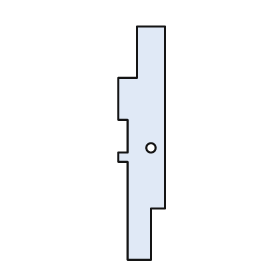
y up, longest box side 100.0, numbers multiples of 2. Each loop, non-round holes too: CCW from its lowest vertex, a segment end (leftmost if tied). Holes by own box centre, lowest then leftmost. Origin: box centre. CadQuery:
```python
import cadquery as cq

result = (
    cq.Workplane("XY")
    .moveTo(-6.0, -50.0)
    .lineTo(4.0, -50.0)
    .lineTo(4.0, -28.0)
    .lineTo(10.0, -28.0)
    .lineTo(10.0, 50.0)
    .lineTo(-2.0, 50.0)
    .lineTo(-2.0, 28.0)
    .lineTo(-10.0, 28.0)
    .lineTo(-10.0, 10.0)
    .lineTo(-6.0, 10.0)
    .lineTo(-6.0, -4.0)
    .lineTo(-10.0, -4.0)
    .lineTo(-10.0, -8.0)
    .lineTo(-6.0, -8.0)
    .close()
    .moveTo(4.0, -2.0)
    .circle(2.0)
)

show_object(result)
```